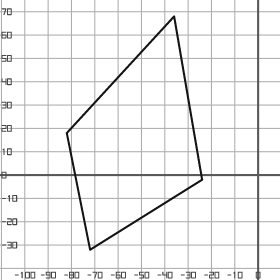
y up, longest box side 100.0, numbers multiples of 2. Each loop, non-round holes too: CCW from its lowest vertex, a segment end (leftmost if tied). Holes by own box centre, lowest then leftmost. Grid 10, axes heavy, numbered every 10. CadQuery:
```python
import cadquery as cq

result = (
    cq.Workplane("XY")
    .moveTo(-72.0, -32.0)
    .lineTo(-24.0, -2.0)
    .lineTo(-36.0, 68.0)
    .lineTo(-82.0, 18.0)
    .close()
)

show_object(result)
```